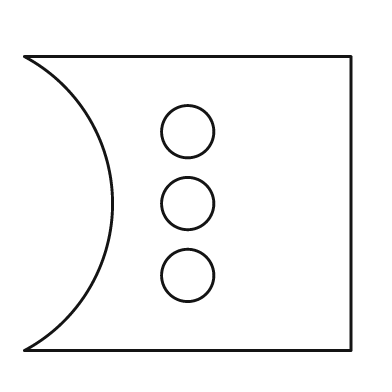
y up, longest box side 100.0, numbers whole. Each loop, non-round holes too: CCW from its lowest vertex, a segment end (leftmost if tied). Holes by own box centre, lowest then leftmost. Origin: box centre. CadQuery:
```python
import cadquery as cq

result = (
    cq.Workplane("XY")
    .moveTo(-50.0, -45.0)
    .lineTo(50.0, -45.0)
    .lineTo(50.0, 45.0)
    .lineTo(-50.0, 45.0)
    .threePointArc((-23.0, 0.0), (-50.0, -45.0))
    .close()
    .moveTo(0.0, -22.0)
    .circle(8.0)
    .moveTo(0.0, 0.0)
    .circle(8.0)
    .moveTo(0.0, 22.0)
    .circle(8.0)
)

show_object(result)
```